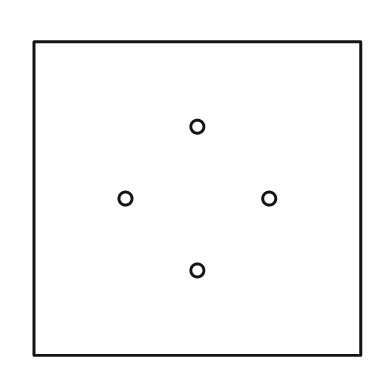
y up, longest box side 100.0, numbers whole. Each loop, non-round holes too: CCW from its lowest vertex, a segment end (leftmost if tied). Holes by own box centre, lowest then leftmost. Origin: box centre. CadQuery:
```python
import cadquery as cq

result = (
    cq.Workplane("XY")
    .moveTo(-50.0, -48.0)
    .lineTo(50.0, -48.0)
    .lineTo(50.0, 48.0)
    .lineTo(-50.0, 48.0)
    .close()
    .moveTo(0.0, -22.0)
    .circle(2.0)
    .moveTo(-22.0, 0.0)
    .circle(2.0)
    .moveTo(22.0, 0.0)
    .circle(2.0)
    .moveTo(0.0, 22.0)
    .circle(2.0)
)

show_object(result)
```